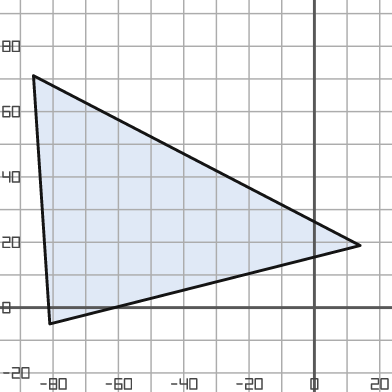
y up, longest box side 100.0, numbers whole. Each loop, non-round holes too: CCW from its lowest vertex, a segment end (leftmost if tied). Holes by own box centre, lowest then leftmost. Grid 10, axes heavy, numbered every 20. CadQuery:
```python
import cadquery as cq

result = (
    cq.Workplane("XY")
    .moveTo(-81.0, -5.0)
    .lineTo(14.0, 19.0)
    .lineTo(-86.0, 71.0)
    .close()
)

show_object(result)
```